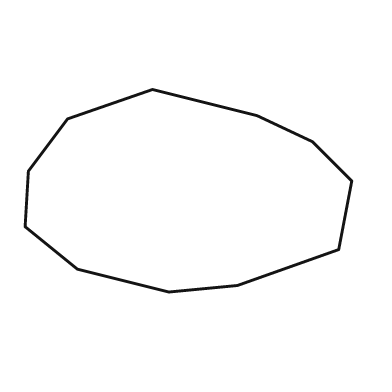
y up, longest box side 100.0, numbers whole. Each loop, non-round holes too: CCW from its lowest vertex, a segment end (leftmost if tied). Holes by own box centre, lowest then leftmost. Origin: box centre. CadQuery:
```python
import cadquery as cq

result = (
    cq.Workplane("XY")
    .moveTo(-6.0, -31.0)
    .lineTo(15.0, -29.0)
    .lineTo(46.0, -18.0)
    .lineTo(50.0, 3.0)
    .lineTo(38.0, 15.0)
    .lineTo(21.0, 23.0)
    .lineTo(-11.0, 31.0)
    .lineTo(-37.0, 22.0)
    .lineTo(-49.0, 6.0)
    .lineTo(-50.0, -11.0)
    .lineTo(-34.0, -24.0)
    .close()
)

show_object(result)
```